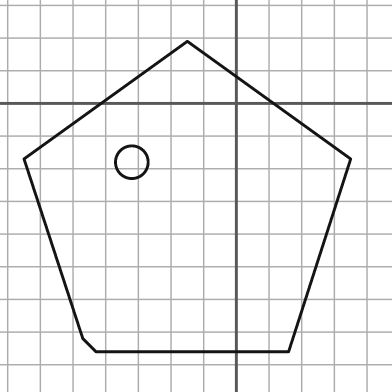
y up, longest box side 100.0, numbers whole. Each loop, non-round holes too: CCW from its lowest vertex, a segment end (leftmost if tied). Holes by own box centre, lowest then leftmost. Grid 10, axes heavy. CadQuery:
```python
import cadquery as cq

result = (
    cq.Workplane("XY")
    .moveTo(-43.0, -76.0)
    .lineTo(16.0, -76.0)
    .lineTo(35.0, -17.0)
    .lineTo(-15.0, 19.0)
    .lineTo(-65.0, -17.0)
    .lineTo(-47.0, -72.0)
    .close()
    .moveTo(-32.0, -18.0)
    .circle(5.0)
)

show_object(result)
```